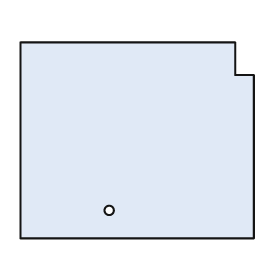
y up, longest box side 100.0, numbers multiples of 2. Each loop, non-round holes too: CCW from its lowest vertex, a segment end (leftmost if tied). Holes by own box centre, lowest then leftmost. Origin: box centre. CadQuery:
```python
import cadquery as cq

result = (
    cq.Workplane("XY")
    .moveTo(-50.0, -42.0)
    .lineTo(50.0, -42.0)
    .lineTo(50.0, 28.0)
    .lineTo(42.0, 28.0)
    .lineTo(42.0, 42.0)
    .lineTo(-50.0, 42.0)
    .close()
    .moveTo(-12.0, -30.0)
    .circle(2.0)
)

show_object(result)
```